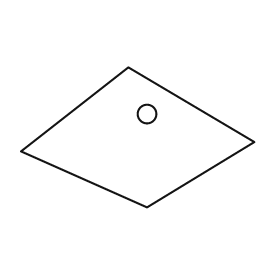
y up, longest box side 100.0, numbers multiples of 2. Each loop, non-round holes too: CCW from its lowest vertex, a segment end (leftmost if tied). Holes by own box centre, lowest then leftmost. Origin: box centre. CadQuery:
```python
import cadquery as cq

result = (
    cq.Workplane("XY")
    .moveTo(4.0, -30.0)
    .lineTo(50.0, -2.0)
    .lineTo(-4.0, 30.0)
    .lineTo(-50.0, -6.0)
    .close()
    .moveTo(4.0, 10.0)
    .circle(4.0)
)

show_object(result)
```